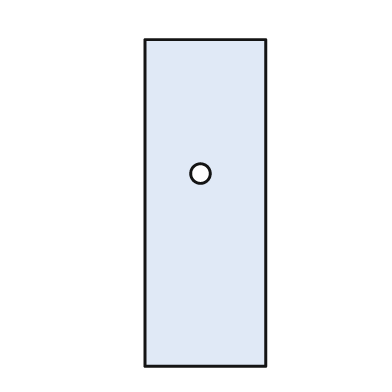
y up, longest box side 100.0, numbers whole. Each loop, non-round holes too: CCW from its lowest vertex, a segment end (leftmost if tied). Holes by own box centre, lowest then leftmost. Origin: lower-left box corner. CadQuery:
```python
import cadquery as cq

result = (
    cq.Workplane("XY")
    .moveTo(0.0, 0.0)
    .lineTo(37.0, 0.0)
    .lineTo(37.0, 100.0)
    .lineTo(0.0, 100.0)
    .close()
    .moveTo(17.0, 59.0)
    .circle(3.0)
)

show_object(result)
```